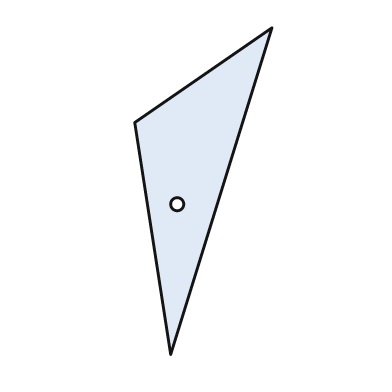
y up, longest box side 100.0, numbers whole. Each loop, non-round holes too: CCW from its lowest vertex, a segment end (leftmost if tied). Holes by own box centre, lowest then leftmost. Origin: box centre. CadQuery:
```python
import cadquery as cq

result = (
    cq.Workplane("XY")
    .moveTo(-10.0, -50.0)
    .lineTo(21.0, 50.0)
    .lineTo(-21.0, 21.0)
    .close()
    .moveTo(-8.0, -4.0)
    .circle(2.0)
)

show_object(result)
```